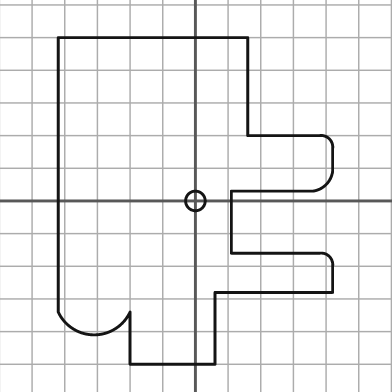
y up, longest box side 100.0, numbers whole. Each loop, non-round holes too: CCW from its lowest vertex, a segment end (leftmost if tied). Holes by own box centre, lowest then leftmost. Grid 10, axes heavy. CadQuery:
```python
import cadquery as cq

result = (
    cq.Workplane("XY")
    .moveTo(-20.0, -50.0)
    .lineTo(6.0, -50.0)
    .lineTo(6.0, -28.0)
    .lineTo(42.0, -28.0)
    .lineTo(42.0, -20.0)
    .threePointArc((41.0, -17.0), (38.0, -16.0))
    .lineTo(11.0, -16.0)
    .lineTo(11.0, 3.0)
    .lineTo(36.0, 3.0)
    .threePointArc((40.0, 5.0), (42.0, 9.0))
    .lineTo(42.0, 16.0)
    .threePointArc((41.0, 19.0), (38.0, 20.0))
    .lineTo(16.0, 20.0)
    .lineTo(16.0, 50.0)
    .lineTo(-42.0, 50.0)
    .lineTo(-42.0, -34.0)
    .threePointArc((-31.0, -41.0), (-20.0, -34.0))
    .close()
    .moveTo(0.0, 0.0)
    .circle(3.0)
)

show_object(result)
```